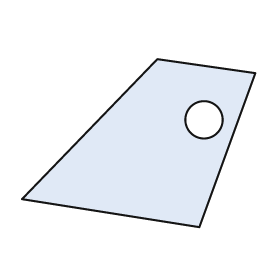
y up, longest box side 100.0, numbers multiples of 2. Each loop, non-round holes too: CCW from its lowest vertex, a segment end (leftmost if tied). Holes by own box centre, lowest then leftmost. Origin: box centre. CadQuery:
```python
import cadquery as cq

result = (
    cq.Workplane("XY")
    .moveTo(26.0, -36.0)
    .lineTo(50.0, 30.0)
    .lineTo(8.0, 36.0)
    .lineTo(-50.0, -24.0)
    .close()
    .moveTo(28.0, 10.0)
    .circle(8.0)
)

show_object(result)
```